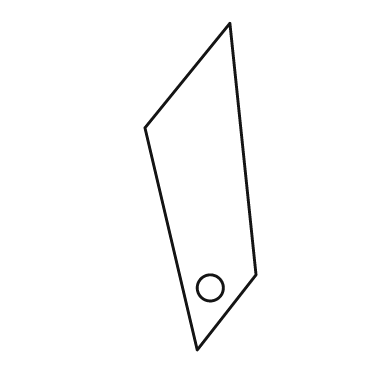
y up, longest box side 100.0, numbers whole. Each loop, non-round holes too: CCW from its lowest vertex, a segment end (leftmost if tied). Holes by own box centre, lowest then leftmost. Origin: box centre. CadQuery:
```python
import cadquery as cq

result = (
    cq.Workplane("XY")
    .moveTo(-1.0, -50.0)
    .lineTo(17.0, -27.0)
    .lineTo(9.0, 50.0)
    .lineTo(-17.0, 18.0)
    .close()
    .moveTo(3.0, -31.0)
    .circle(4.0)
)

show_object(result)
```